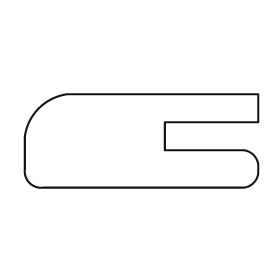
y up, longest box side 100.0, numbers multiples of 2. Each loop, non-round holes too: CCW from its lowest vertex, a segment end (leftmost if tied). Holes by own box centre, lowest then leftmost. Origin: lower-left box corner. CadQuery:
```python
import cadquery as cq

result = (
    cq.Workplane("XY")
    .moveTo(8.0, 0.0)
    .lineTo(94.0, 0.0)
    .threePointArc((98.0, 2.0), (100.0, 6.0))
    .lineTo(100.0, 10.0)
    .threePointArc((98.0, 14.0), (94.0, 16.0))
    .lineTo(60.0, 16.0)
    .lineTo(60.0, 28.0)
    .lineTo(100.0, 28.0)
    .lineTo(100.0, 40.0)
    .lineTo(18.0, 40.0)
    .threePointArc((6.0, 34.0), (0.0, 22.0))
    .lineTo(0.0, 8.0)
    .threePointArc((2.0, 2.0), (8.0, 0.0))
    .close()
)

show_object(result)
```